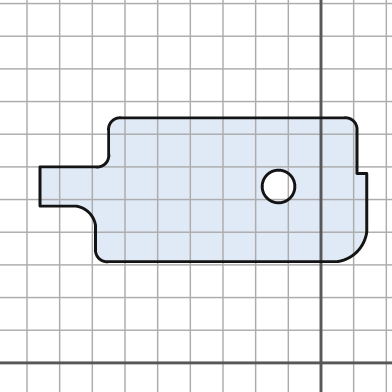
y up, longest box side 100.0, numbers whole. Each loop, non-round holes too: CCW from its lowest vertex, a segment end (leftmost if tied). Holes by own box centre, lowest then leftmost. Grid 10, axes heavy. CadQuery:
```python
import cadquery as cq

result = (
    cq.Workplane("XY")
    .moveTo(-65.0, 31.0)
    .lineTo(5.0, 31.0)
    .threePointArc((11.0, 34.0), (14.0, 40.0))
    .lineTo(14.0, 58.0)
    .lineTo(11.0, 58.0)
    .lineTo(11.0, 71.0)
    .threePointArc((10.0, 74.0), (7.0, 75.0))
    .lineTo(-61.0, 75.0)
    .threePointArc((-64.0, 74.0), (-65.0, 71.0))
    .lineTo(-65.0, 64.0)
    .threePointArc((-66.0, 61.0), (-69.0, 60.0))
    .lineTo(-86.0, 60.0)
    .lineTo(-86.0, 48.0)
    .lineTo(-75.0, 48.0)
    .threePointArc((-71.0, 46.0), (-69.0, 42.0))
    .lineTo(-69.0, 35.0)
    .threePointArc((-68.0, 32.0), (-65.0, 31.0))
    .close()
    .moveTo(-13.0, 54.0)
    .circle(5.0)
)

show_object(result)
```